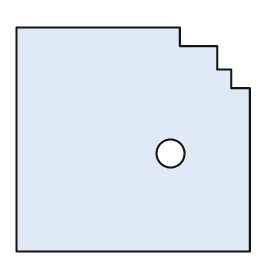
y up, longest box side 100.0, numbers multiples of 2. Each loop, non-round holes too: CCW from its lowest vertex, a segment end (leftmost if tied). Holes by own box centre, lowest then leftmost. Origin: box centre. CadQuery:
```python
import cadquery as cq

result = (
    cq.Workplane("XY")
    .moveTo(-50.0, -48.0)
    .lineTo(50.0, -48.0)
    .lineTo(50.0, 22.0)
    .lineTo(42.0, 22.0)
    .lineTo(42.0, 30.0)
    .lineTo(36.0, 30.0)
    .lineTo(36.0, 40.0)
    .lineTo(20.0, 40.0)
    .lineTo(20.0, 48.0)
    .lineTo(-50.0, 48.0)
    .close()
    .moveTo(16.0, -6.0)
    .circle(6.0)
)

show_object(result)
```